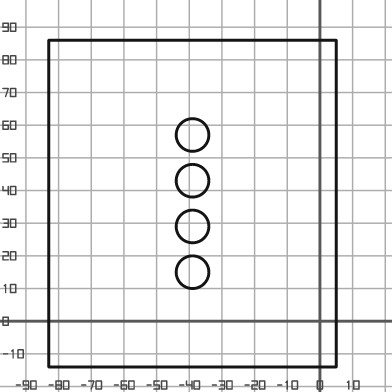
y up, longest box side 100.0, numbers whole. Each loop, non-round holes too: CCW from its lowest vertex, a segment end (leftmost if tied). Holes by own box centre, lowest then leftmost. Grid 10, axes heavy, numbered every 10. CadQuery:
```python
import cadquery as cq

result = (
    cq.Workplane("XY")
    .moveTo(-83.0, -14.0)
    .lineTo(5.0, -14.0)
    .lineTo(5.0, 86.0)
    .lineTo(-83.0, 86.0)
    .close()
    .moveTo(-39.0, 15.0)
    .circle(5.0)
    .moveTo(-39.0, 29.0)
    .circle(5.0)
    .moveTo(-39.0, 43.0)
    .circle(5.0)
    .moveTo(-39.0, 57.0)
    .circle(5.0)
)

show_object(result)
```